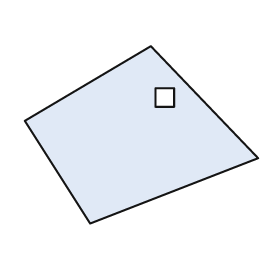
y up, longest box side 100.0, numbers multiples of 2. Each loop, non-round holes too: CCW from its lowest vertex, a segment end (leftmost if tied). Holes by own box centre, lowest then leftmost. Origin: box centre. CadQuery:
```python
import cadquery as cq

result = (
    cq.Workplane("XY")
    .moveTo(-22.0, -38.0)
    .lineTo(50.0, -10.0)
    .lineTo(4.0, 38.0)
    .lineTo(-50.0, 6.0)
    .close()
    .moveTo(6.0, 12.0)
    .lineTo(14.0, 12.0)
    .lineTo(14.0, 20.0)
    .lineTo(6.0, 20.0)
    .close()
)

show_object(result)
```